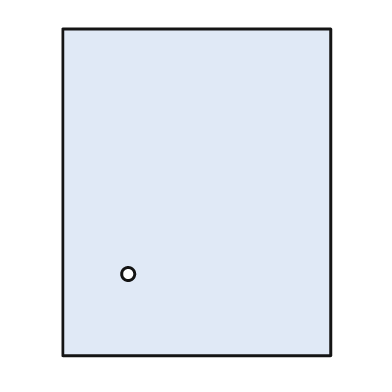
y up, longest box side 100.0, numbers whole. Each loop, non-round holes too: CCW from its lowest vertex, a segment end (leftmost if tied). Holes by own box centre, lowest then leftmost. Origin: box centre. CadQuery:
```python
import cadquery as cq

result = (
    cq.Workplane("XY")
    .moveTo(-41.0, -50.0)
    .lineTo(41.0, -50.0)
    .lineTo(41.0, 50.0)
    .lineTo(-41.0, 50.0)
    .close()
    .moveTo(-21.0, -25.0)
    .circle(2.0)
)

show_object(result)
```